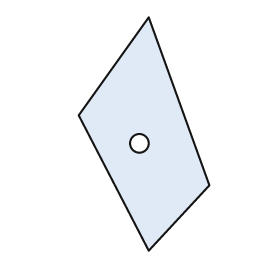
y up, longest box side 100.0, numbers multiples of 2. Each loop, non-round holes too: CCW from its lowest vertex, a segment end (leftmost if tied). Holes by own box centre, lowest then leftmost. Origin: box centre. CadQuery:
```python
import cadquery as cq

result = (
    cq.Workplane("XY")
    .moveTo(2.0, -50.0)
    .lineTo(28.0, -22.0)
    .lineTo(2.0, 50.0)
    .lineTo(-28.0, 8.0)
    .close()
    .moveTo(-2.0, -4.0)
    .circle(4.0)
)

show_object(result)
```